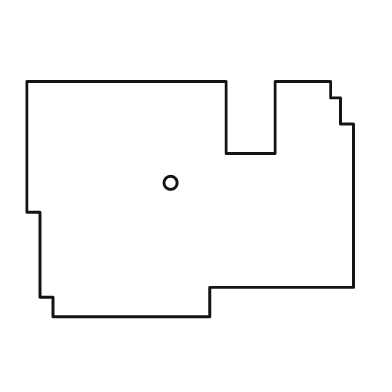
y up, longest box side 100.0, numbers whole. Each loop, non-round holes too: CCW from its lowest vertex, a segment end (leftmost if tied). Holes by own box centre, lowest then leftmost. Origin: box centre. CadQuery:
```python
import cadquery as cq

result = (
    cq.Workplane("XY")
    .moveTo(-42.0, -36.0)
    .lineTo(6.0, -36.0)
    .lineTo(6.0, -27.0)
    .lineTo(50.0, -27.0)
    .lineTo(50.0, 23.0)
    .lineTo(46.0, 23.0)
    .lineTo(46.0, 31.0)
    .lineTo(43.0, 31.0)
    .lineTo(43.0, 36.0)
    .lineTo(26.0, 36.0)
    .lineTo(26.0, 14.0)
    .lineTo(11.0, 14.0)
    .lineTo(11.0, 36.0)
    .lineTo(-50.0, 36.0)
    .lineTo(-50.0, -4.0)
    .lineTo(-46.0, -4.0)
    .lineTo(-46.0, -30.0)
    .lineTo(-42.0, -30.0)
    .close()
    .moveTo(-6.0, 5.0)
    .circle(2.0)
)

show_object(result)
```